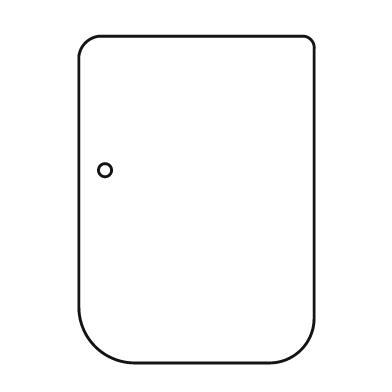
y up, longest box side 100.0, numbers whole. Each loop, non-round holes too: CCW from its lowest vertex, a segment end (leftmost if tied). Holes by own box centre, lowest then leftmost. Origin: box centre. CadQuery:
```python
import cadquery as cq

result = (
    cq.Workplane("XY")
    .moveTo(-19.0, -50.0)
    .lineTo(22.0, -50.0)
    .threePointArc((32.0, -46.0), (36.0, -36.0))
    .lineTo(36.0, 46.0)
    .threePointArc((35.0, 49.0), (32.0, 50.0))
    .lineTo(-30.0, 50.0)
    .threePointArc((-34.0, 48.0), (-36.0, 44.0))
    .lineTo(-36.0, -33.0)
    .threePointArc((-31.0, -45.0), (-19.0, -50.0))
    .close()
    .moveTo(-28.0, 9.0)
    .circle(2.0)
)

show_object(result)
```